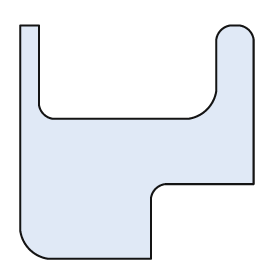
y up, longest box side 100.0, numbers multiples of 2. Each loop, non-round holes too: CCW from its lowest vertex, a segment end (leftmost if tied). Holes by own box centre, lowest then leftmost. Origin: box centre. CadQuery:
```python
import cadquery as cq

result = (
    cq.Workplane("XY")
    .moveTo(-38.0, -50.0)
    .lineTo(6.0, -50.0)
    .lineTo(6.0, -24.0)
    .threePointArc((8.0, -20.0), (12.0, -18.0))
    .lineTo(50.0, -18.0)
    .lineTo(50.0, 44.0)
    .threePointArc((48.0, 48.0), (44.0, 50.0))
    .lineTo(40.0, 50.0)
    .threePointArc((36.0, 48.0), (34.0, 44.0))
    .lineTo(34.0, 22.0)
    .threePointArc((30.0, 14.0), (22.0, 10.0))
    .lineTo(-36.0, 10.0)
    .threePointArc((-40.0, 12.0), (-42.0, 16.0))
    .lineTo(-42.0, 50.0)
    .lineTo(-50.0, 50.0)
    .lineTo(-50.0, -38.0)
    .threePointArc((-46.0, -46.0), (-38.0, -50.0))
    .close()
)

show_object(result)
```